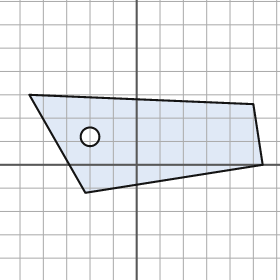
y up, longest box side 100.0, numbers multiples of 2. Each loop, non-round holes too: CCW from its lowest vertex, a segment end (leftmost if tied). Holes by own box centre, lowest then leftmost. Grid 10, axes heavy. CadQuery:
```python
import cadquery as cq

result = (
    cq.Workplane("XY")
    .moveTo(-22.0, -12.0)
    .lineTo(54.0, 0.0)
    .lineTo(50.0, 26.0)
    .lineTo(-46.0, 30.0)
    .close()
    .moveTo(-20.0, 12.0)
    .circle(4.0)
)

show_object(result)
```